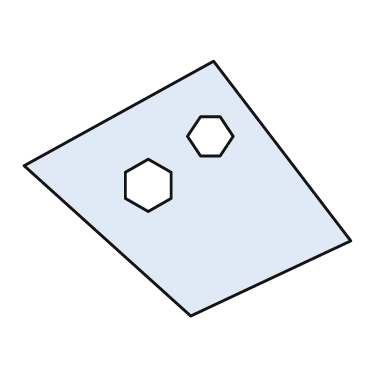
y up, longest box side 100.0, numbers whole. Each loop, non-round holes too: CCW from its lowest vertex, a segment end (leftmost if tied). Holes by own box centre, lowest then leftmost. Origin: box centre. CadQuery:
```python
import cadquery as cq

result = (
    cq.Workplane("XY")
    .moveTo(1.0, -39.0)
    .lineTo(50.0, -16.0)
    .lineTo(8.0, 39.0)
    .lineTo(-50.0, 7.0)
    .close()
    .moveTo(-12.0, -7.0)
    .lineTo(-5.0, -3.0)
    .lineTo(-5.0, 5.0)
    .lineTo(-12.0, 9.0)
    .lineTo(-19.0, 5.0)
    .lineTo(-19.0, -3.0)
    .close()
    .moveTo(4.0, 10.0)
    .lineTo(10.0, 10.0)
    .lineTo(14.0, 16.0)
    .lineTo(10.0, 22.0)
    .lineTo(4.0, 22.0)
    .lineTo(0.0, 16.0)
    .close()
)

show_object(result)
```